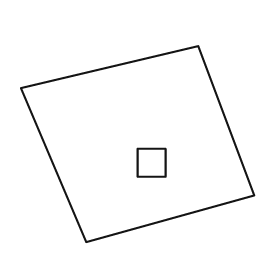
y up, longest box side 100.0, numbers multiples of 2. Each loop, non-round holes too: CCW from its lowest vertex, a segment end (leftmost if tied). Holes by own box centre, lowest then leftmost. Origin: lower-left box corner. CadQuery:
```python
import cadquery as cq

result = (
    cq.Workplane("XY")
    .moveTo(28.0, 0.0)
    .lineTo(100.0, 20.0)
    .lineTo(76.0, 84.0)
    .lineTo(0.0, 66.0)
    .close()
    .moveTo(50.0, 28.0)
    .lineTo(62.0, 28.0)
    .lineTo(62.0, 40.0)
    .lineTo(50.0, 40.0)
    .close()
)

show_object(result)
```